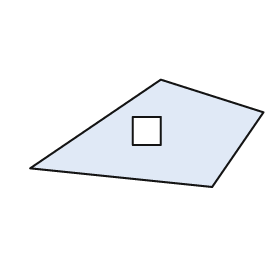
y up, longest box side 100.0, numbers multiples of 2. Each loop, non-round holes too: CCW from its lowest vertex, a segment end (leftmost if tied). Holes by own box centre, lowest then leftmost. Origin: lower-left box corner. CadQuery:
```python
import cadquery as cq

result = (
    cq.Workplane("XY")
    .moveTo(78.0, 0.0)
    .lineTo(100.0, 32.0)
    .lineTo(56.0, 46.0)
    .lineTo(0.0, 8.0)
    .close()
    .moveTo(44.0, 18.0)
    .lineTo(56.0, 18.0)
    .lineTo(56.0, 30.0)
    .lineTo(44.0, 30.0)
    .close()
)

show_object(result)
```